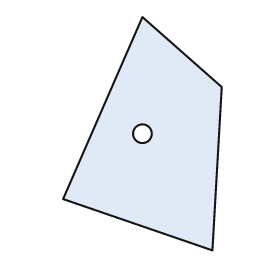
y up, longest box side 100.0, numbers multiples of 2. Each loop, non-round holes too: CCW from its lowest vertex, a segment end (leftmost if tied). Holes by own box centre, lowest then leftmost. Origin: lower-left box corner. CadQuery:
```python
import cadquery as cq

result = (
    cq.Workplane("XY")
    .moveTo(64.0, 0.0)
    .lineTo(68.0, 70.0)
    .lineTo(34.0, 100.0)
    .lineTo(0.0, 22.0)
    .close()
    .moveTo(34.0, 50.0)
    .circle(4.0)
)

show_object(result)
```